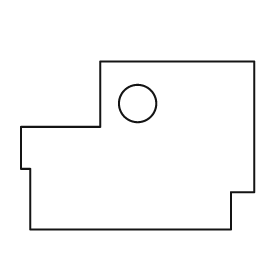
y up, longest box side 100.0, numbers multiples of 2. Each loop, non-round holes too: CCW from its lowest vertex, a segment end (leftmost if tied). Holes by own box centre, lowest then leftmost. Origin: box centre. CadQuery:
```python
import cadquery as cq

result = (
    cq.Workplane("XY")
    .moveTo(-46.0, -36.0)
    .lineTo(40.0, -36.0)
    .lineTo(40.0, -20.0)
    .lineTo(50.0, -20.0)
    .lineTo(50.0, 36.0)
    .lineTo(-16.0, 36.0)
    .lineTo(-16.0, 8.0)
    .lineTo(-50.0, 8.0)
    .lineTo(-50.0, -10.0)
    .lineTo(-46.0, -10.0)
    .close()
    .moveTo(0.0, 18.0)
    .circle(8.0)
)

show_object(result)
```